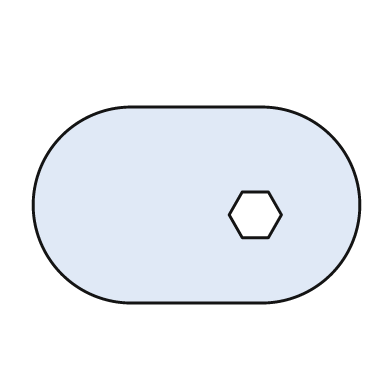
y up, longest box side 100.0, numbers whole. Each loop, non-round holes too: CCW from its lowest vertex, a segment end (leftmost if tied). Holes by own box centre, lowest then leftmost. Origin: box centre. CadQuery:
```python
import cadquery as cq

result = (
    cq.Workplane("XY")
    .moveTo(-20.0, -30.0)
    .lineTo(20.0, -30.0)
    .threePointArc((50.0, 0.0), (20.0, 30.0))
    .lineTo(-20.0, 30.0)
    .threePointArc((-50.0, 0.0), (-20.0, -30.0))
    .close()
    .moveTo(14.0, -10.0)
    .lineTo(22.0, -10.0)
    .lineTo(26.0, -3.0)
    .lineTo(22.0, 4.0)
    .lineTo(14.0, 4.0)
    .lineTo(10.0, -3.0)
    .close()
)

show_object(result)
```